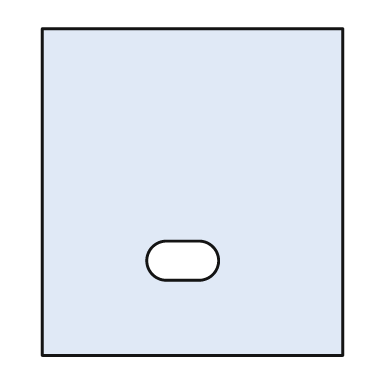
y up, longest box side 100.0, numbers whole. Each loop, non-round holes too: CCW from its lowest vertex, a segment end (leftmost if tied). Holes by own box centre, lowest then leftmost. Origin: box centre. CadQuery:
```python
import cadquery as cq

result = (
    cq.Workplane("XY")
    .moveTo(-46.0, -50.0)
    .lineTo(46.0, -50.0)
    .lineTo(46.0, 50.0)
    .lineTo(-46.0, 50.0)
    .close()
    .moveTo(-8.0, -27.0)
    .lineTo(2.0, -27.0)
    .threePointArc((8.0, -21.0), (2.0, -15.0))
    .lineTo(-8.0, -15.0)
    .threePointArc((-14.0, -21.0), (-8.0, -27.0))
    .close()
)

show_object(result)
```